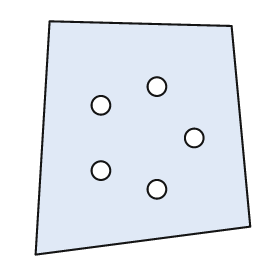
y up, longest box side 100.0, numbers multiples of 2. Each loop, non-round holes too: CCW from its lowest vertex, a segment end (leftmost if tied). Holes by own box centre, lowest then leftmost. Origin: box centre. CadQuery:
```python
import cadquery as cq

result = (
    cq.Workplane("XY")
    .moveTo(-46.0, -50.0)
    .lineTo(46.0, -38.0)
    .lineTo(38.0, 48.0)
    .lineTo(-40.0, 50.0)
    .close()
    .moveTo(6.0, -22.0)
    .circle(4.0)
    .moveTo(-18.0, -14.0)
    .circle(4.0)
    .moveTo(22.0, 0.0)
    .circle(4.0)
    .moveTo(-18.0, 14.0)
    .circle(4.0)
    .moveTo(6.0, 22.0)
    .circle(4.0)
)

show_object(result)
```